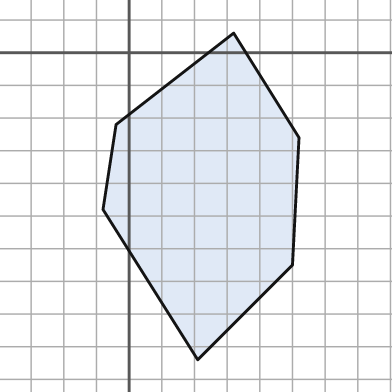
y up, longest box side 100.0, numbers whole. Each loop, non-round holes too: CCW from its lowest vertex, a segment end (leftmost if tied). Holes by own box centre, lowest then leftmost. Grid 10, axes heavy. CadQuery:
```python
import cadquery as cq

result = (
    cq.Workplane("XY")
    .moveTo(21.0, -94.0)
    .lineTo(50.0, -65.0)
    .lineTo(52.0, -26.0)
    .lineTo(32.0, 6.0)
    .lineTo(-4.0, -22.0)
    .lineTo(-8.0, -48.0)
    .close()
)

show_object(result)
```